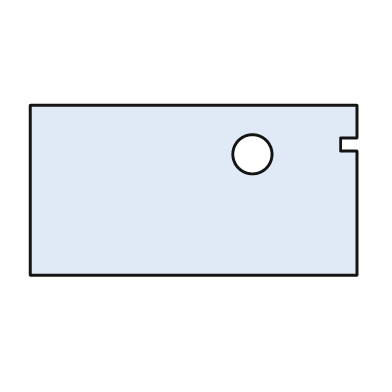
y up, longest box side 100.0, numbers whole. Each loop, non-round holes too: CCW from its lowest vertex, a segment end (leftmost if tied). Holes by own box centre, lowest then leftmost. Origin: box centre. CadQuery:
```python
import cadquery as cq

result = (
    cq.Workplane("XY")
    .moveTo(-50.0, -26.0)
    .lineTo(50.0, -26.0)
    .lineTo(50.0, 12.0)
    .lineTo(45.0, 12.0)
    .lineTo(45.0, 16.0)
    .lineTo(50.0, 16.0)
    .lineTo(50.0, 26.0)
    .lineTo(-50.0, 26.0)
    .close()
    .moveTo(18.0, 11.0)
    .circle(6.0)
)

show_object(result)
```